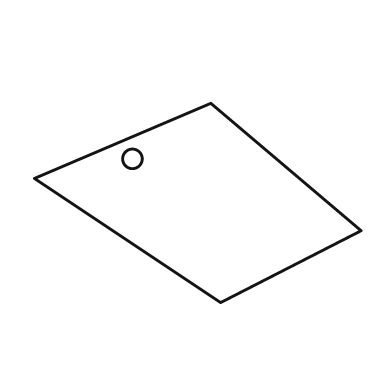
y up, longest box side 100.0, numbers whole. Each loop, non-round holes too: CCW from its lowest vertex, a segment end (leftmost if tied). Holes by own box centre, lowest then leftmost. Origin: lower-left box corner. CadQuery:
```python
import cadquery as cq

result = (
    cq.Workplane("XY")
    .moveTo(57.0, 0.0)
    .lineTo(100.0, 22.0)
    .lineTo(54.0, 61.0)
    .lineTo(0.0, 38.0)
    .close()
    .moveTo(30.0, 44.0)
    .circle(3.0)
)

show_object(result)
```